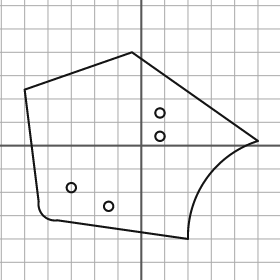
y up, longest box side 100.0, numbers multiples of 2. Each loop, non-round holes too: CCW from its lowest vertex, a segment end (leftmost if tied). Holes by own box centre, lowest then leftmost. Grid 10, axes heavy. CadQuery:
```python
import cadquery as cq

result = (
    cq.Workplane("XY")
    .moveTo(20.0, -40.0)
    .threePointArc((28.0, -14.0), (50.0, 2.0))
    .lineTo(-4.0, 40.0)
    .lineTo(-50.0, 24.0)
    .lineTo(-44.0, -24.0)
    .threePointArc((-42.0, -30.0), (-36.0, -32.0))
    .close()
    .moveTo(-14.0, -26.0)
    .circle(2.0)
    .moveTo(-30.0, -18.0)
    .circle(2.0)
    .moveTo(8.0, 4.0)
    .circle(2.0)
    .moveTo(8.0, 14.0)
    .circle(2.0)
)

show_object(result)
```